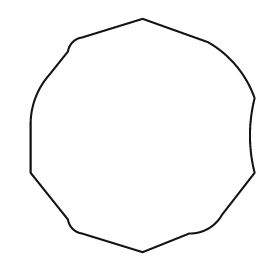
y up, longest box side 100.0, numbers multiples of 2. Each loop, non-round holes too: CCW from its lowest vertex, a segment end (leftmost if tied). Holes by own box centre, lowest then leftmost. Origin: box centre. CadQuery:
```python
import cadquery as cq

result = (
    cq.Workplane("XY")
    .moveTo(0.0, -50.0)
    .lineTo(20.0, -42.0)
    .threePointArc((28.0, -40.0), (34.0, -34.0))
    .lineTo(48.0, -16.0)
    .threePointArc((46.0, 0.0), (48.0, 16.0))
    .threePointArc((40.0, 30.0), (28.0, 40.0))
    .lineTo(0.0, 50.0)
    .lineTo(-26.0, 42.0)
    .threePointArc((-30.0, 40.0), (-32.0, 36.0))
    .lineTo(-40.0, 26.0)
    .threePointArc((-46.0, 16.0), (-48.0, 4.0))
    .lineTo(-48.0, -16.0)
    .lineTo(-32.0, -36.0)
    .threePointArc((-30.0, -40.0), (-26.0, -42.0))
    .close()
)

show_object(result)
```